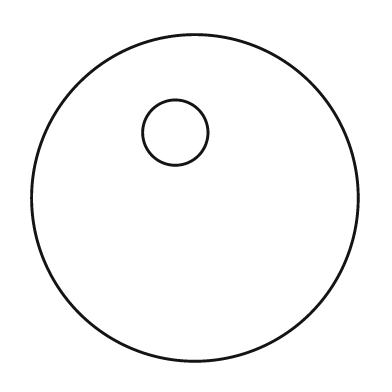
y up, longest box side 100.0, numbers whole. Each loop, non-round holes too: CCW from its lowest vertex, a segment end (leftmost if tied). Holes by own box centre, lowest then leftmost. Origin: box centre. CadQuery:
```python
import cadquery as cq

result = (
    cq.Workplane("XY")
    .moveTo(0.0, 0.0)
    .circle(50.0)
    .moveTo(-6.0, 20.0)
    .circle(10.0)
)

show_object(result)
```